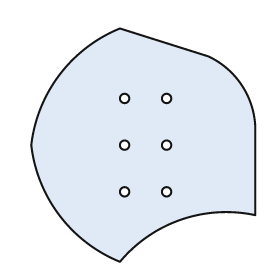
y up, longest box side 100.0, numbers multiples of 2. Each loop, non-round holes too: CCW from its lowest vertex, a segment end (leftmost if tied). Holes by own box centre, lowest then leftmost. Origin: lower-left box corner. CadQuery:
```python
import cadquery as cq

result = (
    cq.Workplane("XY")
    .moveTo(38.0, 0.0)
    .threePointArc((64.0, 18.0), (96.0, 20.0))
    .lineTo(96.0, 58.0)
    .threePointArc((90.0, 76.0), (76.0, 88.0))
    .lineTo(38.0, 100.0)
    .threePointArc((12.0, 80.0), (0.0, 50.0))
    .threePointArc((12.0, 20.0), (38.0, 0.0))
    .close()
    .moveTo(40.0, 30.0)
    .circle(2.0)
    .moveTo(58.0, 30.0)
    .circle(2.0)
    .moveTo(40.0, 50.0)
    .circle(2.0)
    .moveTo(58.0, 50.0)
    .circle(2.0)
    .moveTo(40.0, 70.0)
    .circle(2.0)
    .moveTo(58.0, 70.0)
    .circle(2.0)
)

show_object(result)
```